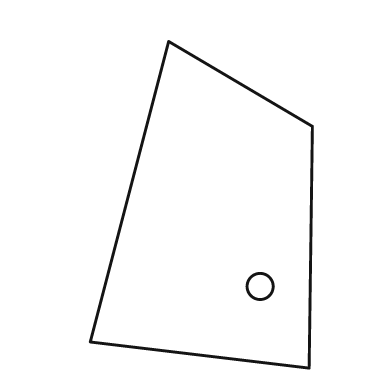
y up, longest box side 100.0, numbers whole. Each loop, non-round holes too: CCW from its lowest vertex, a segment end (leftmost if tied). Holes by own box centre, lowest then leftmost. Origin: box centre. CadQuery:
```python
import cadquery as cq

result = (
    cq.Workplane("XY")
    .moveTo(33.0, -50.0)
    .lineTo(34.0, 24.0)
    .lineTo(-10.0, 50.0)
    .lineTo(-34.0, -42.0)
    .close()
    .moveTo(18.0, -25.0)
    .circle(4.0)
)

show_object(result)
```